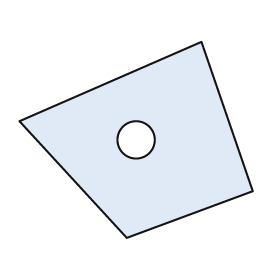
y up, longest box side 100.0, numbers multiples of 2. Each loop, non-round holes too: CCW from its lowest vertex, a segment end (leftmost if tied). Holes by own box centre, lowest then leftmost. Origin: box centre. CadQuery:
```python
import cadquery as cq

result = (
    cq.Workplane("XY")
    .moveTo(-4.0, -42.0)
    .lineTo(50.0, -22.0)
    .lineTo(28.0, 42.0)
    .lineTo(-50.0, 8.0)
    .close()
    .moveTo(0.0, 0.0)
    .circle(8.0)
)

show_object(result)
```